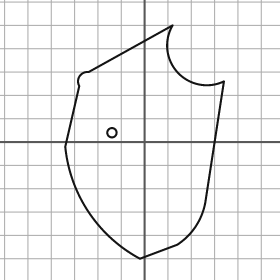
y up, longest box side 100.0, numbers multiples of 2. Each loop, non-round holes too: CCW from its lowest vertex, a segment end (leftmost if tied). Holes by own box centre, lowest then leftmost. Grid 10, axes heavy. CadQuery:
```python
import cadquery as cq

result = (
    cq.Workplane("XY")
    .moveTo(-2.0, -50.0)
    .lineTo(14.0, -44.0)
    .threePointArc((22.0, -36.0), (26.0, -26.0))
    .lineTo(34.0, 26.0)
    .threePointArc((14.0, 30.0), (12.0, 50.0))
    .lineTo(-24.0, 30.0)
    .threePointArc((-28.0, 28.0), (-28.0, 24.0))
    .lineTo(-34.0, -2.0)
    .threePointArc((-24.0, -30.0), (-2.0, -50.0))
    .close()
    .moveTo(-14.0, 4.0)
    .circle(2.0)
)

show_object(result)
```